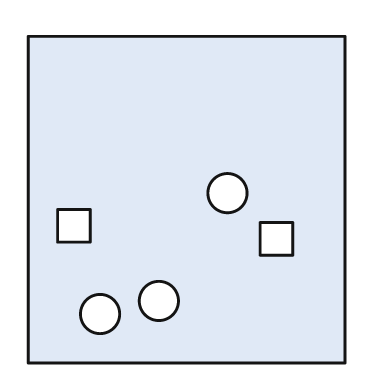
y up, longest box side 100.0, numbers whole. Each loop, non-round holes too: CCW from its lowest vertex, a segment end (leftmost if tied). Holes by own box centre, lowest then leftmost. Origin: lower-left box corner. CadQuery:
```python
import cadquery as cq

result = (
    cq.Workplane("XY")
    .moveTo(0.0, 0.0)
    .lineTo(97.0, 0.0)
    .lineTo(97.0, 100.0)
    .lineTo(0.0, 100.0)
    .close()
    .moveTo(22.0, 15.0)
    .circle(6.0)
    .moveTo(40.0, 19.0)
    .circle(6.0)
    .moveTo(71.0, 33.0)
    .lineTo(81.0, 33.0)
    .lineTo(81.0, 43.0)
    .lineTo(71.0, 43.0)
    .close()
    .moveTo(9.0, 37.0)
    .lineTo(19.0, 37.0)
    .lineTo(19.0, 47.0)
    .lineTo(9.0, 47.0)
    .close()
    .moveTo(61.0, 52.0)
    .circle(6.0)
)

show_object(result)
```